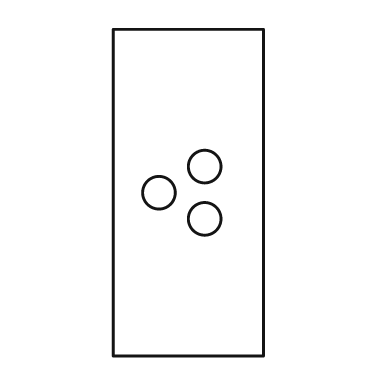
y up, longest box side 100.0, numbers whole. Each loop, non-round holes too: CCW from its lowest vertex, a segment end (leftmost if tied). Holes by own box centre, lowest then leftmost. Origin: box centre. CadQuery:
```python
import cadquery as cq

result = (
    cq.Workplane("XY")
    .moveTo(-23.0, -50.0)
    .lineTo(23.0, -50.0)
    .lineTo(23.0, 50.0)
    .lineTo(-23.0, 50.0)
    .close()
    .moveTo(5.0, -8.0)
    .circle(5.0)
    .moveTo(-9.0, 0.0)
    .circle(5.0)
    .moveTo(5.0, 8.0)
    .circle(5.0)
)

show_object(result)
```